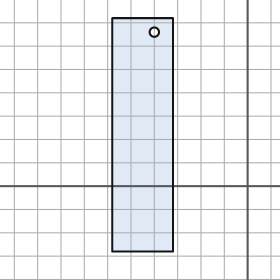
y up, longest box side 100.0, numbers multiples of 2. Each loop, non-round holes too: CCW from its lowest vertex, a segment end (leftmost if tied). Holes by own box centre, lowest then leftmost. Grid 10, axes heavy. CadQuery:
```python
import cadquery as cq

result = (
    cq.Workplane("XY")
    .moveTo(-58.0, -28.0)
    .lineTo(-32.0, -28.0)
    .lineTo(-32.0, 72.0)
    .lineTo(-58.0, 72.0)
    .close()
    .moveTo(-40.0, 66.0)
    .circle(2.0)
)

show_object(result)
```